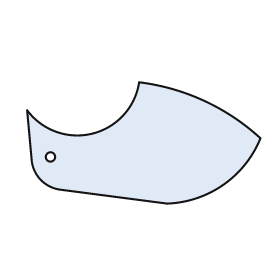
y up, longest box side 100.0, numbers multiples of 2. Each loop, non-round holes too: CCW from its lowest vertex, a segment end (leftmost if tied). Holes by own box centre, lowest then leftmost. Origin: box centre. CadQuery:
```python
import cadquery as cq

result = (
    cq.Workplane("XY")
    .moveTo(10.0, -26.0)
    .threePointArc((34.0, -18.0), (50.0, 2.0))
    .threePointArc((26.0, 18.0), (-2.0, 26.0))
    .threePointArc((-22.0, 4.0), (-50.0, 14.0))
    .lineTo(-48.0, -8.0)
    .threePointArc((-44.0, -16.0), (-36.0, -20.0))
    .close()
    .moveTo(-40.0, -6.0)
    .circle(2.0)
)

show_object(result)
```